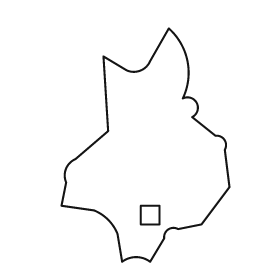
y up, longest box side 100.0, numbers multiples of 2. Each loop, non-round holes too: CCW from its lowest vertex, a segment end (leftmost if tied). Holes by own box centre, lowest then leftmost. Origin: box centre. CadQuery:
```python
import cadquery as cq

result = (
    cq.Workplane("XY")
    .moveTo(-10.0, -50.0)
    .threePointArc((-4.0, -48.0), (2.0, -50.0))
    .lineTo(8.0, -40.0)
    .threePointArc((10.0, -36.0), (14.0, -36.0))
    .lineTo(24.0, -34.0)
    .lineTo(36.0, -18.0)
    .lineTo(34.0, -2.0)
    .threePointArc((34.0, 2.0), (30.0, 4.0))
    .lineTo(20.0, 12.0)
    .threePointArc((22.0, 18.0), (16.0, 20.0))
    .threePointArc((18.0, 36.0), (10.0, 50.0))
    .lineTo(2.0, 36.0)
    .threePointArc((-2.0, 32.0), (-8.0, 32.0))
    .lineTo(-18.0, 38.0)
    .lineTo(-16.0, 6.0)
    .lineTo(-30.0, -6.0)
    .threePointArc((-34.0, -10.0), (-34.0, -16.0))
    .lineTo(-36.0, -26.0)
    .lineTo(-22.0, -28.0)
    .threePointArc((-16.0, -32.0), (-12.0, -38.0))
    .close()
    .moveTo(-2.0, -34.0)
    .lineTo(6.0, -34.0)
    .lineTo(6.0, -26.0)
    .lineTo(-2.0, -26.0)
    .close()
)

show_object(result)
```